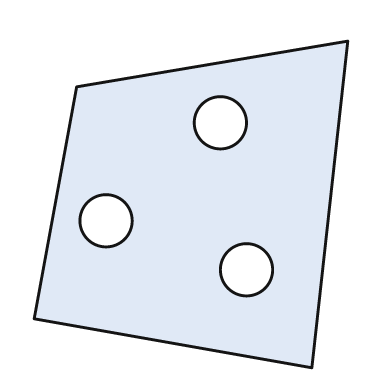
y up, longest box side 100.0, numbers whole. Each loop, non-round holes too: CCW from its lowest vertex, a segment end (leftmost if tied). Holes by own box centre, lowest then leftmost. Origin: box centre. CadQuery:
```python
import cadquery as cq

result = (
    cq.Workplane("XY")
    .moveTo(37.0, -50.0)
    .lineTo(48.0, 50.0)
    .lineTo(-35.0, 36.0)
    .lineTo(-48.0, -35.0)
    .close()
    .moveTo(17.0, -20.0)
    .circle(8.0)
    .moveTo(-26.0, -5.0)
    .circle(8.0)
    .moveTo(9.0, 25.0)
    .circle(8.0)
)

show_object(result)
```